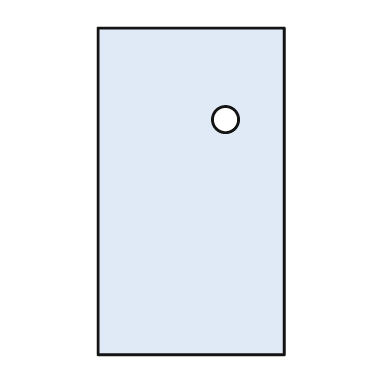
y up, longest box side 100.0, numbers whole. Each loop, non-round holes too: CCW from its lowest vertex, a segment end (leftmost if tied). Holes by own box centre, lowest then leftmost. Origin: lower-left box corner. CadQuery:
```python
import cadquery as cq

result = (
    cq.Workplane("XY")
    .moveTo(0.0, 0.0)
    .lineTo(57.0, 0.0)
    .lineTo(57.0, 100.0)
    .lineTo(0.0, 100.0)
    .close()
    .moveTo(39.0, 72.0)
    .circle(4.0)
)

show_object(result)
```